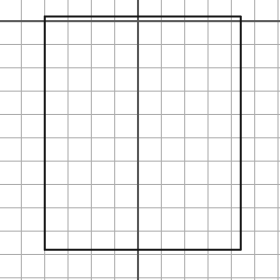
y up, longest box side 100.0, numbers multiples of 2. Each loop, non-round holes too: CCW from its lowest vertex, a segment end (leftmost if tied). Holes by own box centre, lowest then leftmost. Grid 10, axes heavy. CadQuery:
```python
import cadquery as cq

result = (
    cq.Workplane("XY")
    .moveTo(-40.0, -98.0)
    .lineTo(44.0, -98.0)
    .lineTo(44.0, 2.0)
    .lineTo(-40.0, 2.0)
    .close()
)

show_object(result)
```